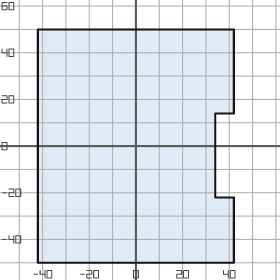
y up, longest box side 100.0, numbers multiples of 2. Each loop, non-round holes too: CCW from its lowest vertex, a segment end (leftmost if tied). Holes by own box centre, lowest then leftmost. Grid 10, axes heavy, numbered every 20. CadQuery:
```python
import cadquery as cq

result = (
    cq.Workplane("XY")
    .moveTo(-42.0, -50.0)
    .lineTo(42.0, -50.0)
    .lineTo(42.0, -22.0)
    .lineTo(34.0, -22.0)
    .lineTo(34.0, 14.0)
    .lineTo(42.0, 14.0)
    .lineTo(42.0, 50.0)
    .lineTo(-42.0, 50.0)
    .close()
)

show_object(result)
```